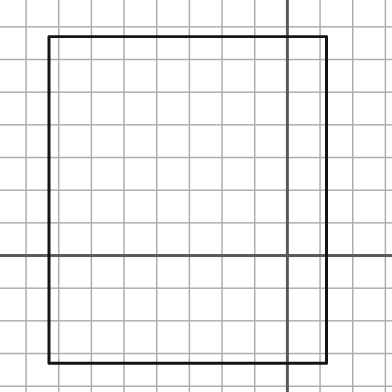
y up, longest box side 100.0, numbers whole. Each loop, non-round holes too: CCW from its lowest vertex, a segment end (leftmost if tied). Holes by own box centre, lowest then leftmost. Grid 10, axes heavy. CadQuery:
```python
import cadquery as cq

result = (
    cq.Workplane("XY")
    .moveTo(-73.0, -33.0)
    .lineTo(12.0, -33.0)
    .lineTo(12.0, 67.0)
    .lineTo(-73.0, 67.0)
    .close()
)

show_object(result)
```